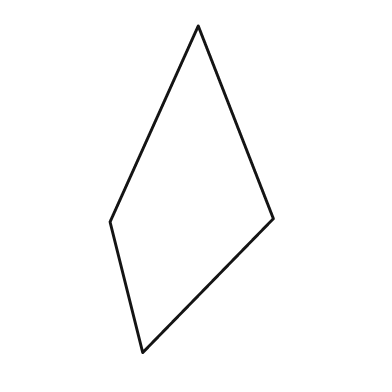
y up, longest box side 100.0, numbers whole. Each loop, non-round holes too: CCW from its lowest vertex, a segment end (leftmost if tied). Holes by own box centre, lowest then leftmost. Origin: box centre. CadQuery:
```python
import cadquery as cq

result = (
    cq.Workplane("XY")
    .moveTo(-15.0, -50.0)
    .lineTo(25.0, -9.0)
    .lineTo(2.0, 50.0)
    .lineTo(-25.0, -10.0)
    .close()
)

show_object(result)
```